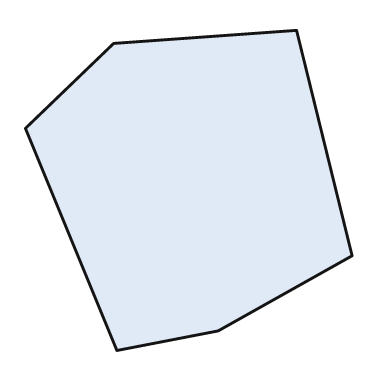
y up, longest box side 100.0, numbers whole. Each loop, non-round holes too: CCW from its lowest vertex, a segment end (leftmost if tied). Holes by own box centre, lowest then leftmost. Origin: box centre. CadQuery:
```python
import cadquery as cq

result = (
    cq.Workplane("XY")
    .moveTo(-22.0, -49.0)
    .lineTo(9.0, -43.0)
    .lineTo(50.0, -20.0)
    .lineTo(33.0, 49.0)
    .lineTo(-23.0, 45.0)
    .lineTo(-50.0, 19.0)
    .close()
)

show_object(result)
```